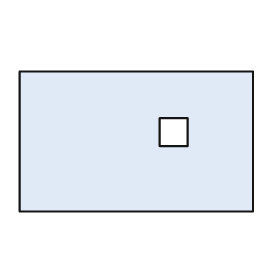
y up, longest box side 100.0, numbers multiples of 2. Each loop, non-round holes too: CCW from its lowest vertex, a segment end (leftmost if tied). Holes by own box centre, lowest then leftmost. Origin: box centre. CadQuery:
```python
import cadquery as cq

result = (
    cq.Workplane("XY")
    .moveTo(-50.0, -30.0)
    .lineTo(50.0, -30.0)
    .lineTo(50.0, 30.0)
    .lineTo(-50.0, 30.0)
    .close()
    .moveTo(10.0, -2.0)
    .lineTo(22.0, -2.0)
    .lineTo(22.0, 10.0)
    .lineTo(10.0, 10.0)
    .close()
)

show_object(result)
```